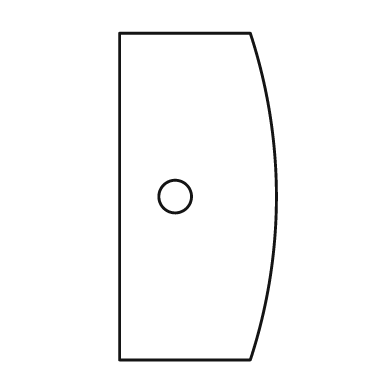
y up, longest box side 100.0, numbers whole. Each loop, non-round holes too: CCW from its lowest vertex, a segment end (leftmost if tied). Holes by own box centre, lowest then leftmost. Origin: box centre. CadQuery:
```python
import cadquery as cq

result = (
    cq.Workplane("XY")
    .moveTo(-24.0, -50.0)
    .lineTo(16.0, -50.0)
    .threePointArc((24.0, 0.0), (16.0, 50.0))
    .lineTo(-24.0, 50.0)
    .close()
    .moveTo(-7.0, 0.0)
    .circle(5.0)
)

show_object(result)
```